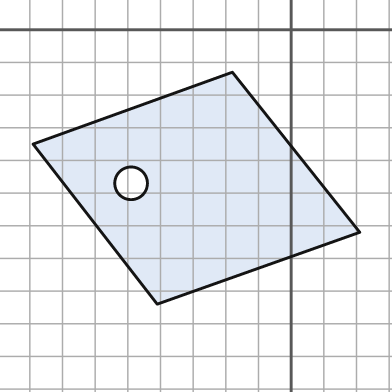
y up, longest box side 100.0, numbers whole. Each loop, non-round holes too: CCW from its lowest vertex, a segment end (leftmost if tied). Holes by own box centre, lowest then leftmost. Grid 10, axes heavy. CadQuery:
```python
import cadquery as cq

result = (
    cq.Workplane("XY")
    .moveTo(-41.0, -84.0)
    .lineTo(21.0, -62.0)
    .lineTo(-18.0, -13.0)
    .lineTo(-79.0, -35.0)
    .close()
    .moveTo(-49.0, -47.0)
    .circle(5.0)
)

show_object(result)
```